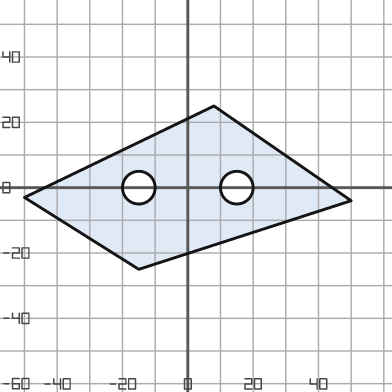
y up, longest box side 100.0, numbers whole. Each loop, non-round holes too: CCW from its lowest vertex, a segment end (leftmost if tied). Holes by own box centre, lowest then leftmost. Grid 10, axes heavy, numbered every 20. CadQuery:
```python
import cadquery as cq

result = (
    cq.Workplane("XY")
    .moveTo(-15.0, -25.0)
    .lineTo(50.0, -4.0)
    .lineTo(8.0, 25.0)
    .lineTo(-50.0, -3.0)
    .close()
    .moveTo(-15.0, 0.0)
    .circle(5.0)
    .moveTo(15.0, 0.0)
    .circle(5.0)
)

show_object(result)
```